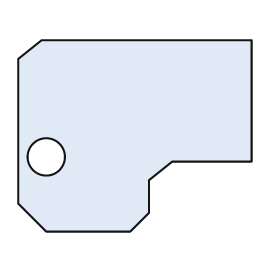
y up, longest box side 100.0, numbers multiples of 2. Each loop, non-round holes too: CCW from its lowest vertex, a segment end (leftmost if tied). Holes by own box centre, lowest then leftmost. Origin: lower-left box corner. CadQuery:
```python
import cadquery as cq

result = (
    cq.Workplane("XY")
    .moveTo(12.0, 0.0)
    .lineTo(48.0, 0.0)
    .lineTo(56.0, 8.0)
    .lineTo(56.0, 22.0)
    .lineTo(66.0, 30.0)
    .lineTo(100.0, 30.0)
    .lineTo(100.0, 82.0)
    .lineTo(10.0, 82.0)
    .lineTo(0.0, 74.0)
    .lineTo(0.0, 12.0)
    .close()
    .moveTo(12.0, 32.0)
    .circle(8.0)
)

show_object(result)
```